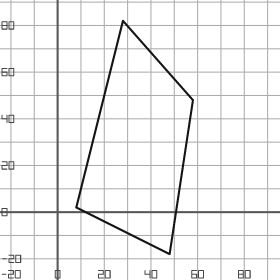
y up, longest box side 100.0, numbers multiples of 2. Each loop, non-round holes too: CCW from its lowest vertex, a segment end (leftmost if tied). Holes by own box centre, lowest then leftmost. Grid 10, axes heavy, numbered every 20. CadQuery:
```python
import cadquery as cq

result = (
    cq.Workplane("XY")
    .moveTo(48.0, -18.0)
    .lineTo(58.0, 48.0)
    .lineTo(28.0, 82.0)
    .lineTo(8.0, 2.0)
    .close()
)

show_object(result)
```